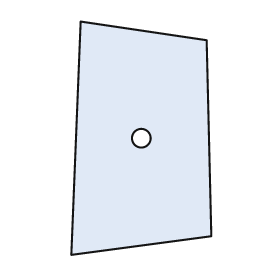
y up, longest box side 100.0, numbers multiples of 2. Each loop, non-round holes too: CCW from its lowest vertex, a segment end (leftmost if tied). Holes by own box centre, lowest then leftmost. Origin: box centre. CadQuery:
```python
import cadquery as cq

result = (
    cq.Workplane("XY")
    .moveTo(-30.0, -50.0)
    .lineTo(30.0, -42.0)
    .lineTo(28.0, 42.0)
    .lineTo(-26.0, 50.0)
    .close()
    .moveTo(0.0, 0.0)
    .circle(4.0)
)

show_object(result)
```